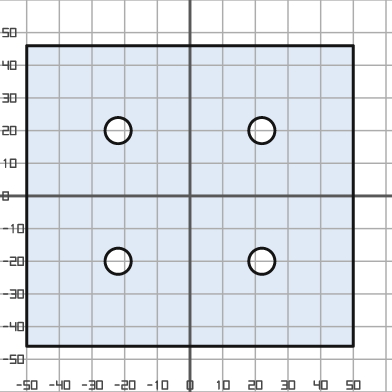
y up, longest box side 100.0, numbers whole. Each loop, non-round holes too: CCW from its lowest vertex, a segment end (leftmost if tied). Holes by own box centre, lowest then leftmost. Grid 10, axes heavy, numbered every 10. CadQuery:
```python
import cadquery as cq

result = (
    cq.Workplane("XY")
    .moveTo(-50.0, -46.0)
    .lineTo(50.0, -46.0)
    .lineTo(50.0, 46.0)
    .lineTo(-50.0, 46.0)
    .close()
    .moveTo(-22.0, -20.0)
    .circle(4.0)
    .moveTo(22.0, -20.0)
    .circle(4.0)
    .moveTo(-22.0, 20.0)
    .circle(4.0)
    .moveTo(22.0, 20.0)
    .circle(4.0)
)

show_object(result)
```